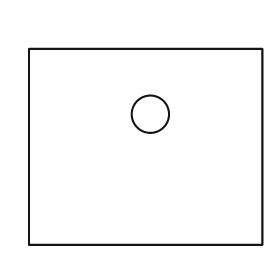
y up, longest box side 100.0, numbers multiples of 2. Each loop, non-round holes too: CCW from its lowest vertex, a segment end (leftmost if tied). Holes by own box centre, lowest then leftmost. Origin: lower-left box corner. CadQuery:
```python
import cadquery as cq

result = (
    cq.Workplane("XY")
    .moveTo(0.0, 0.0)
    .lineTo(100.0, 0.0)
    .lineTo(100.0, 84.0)
    .lineTo(0.0, 84.0)
    .close()
    .moveTo(52.0, 56.0)
    .circle(8.0)
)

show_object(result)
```